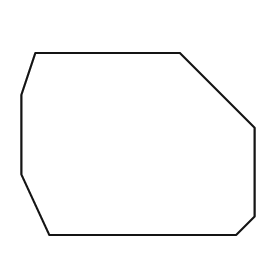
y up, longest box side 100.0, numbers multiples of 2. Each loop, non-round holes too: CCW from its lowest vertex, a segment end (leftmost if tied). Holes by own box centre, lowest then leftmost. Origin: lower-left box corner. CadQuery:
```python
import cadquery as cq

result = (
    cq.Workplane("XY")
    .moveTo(12.0, 0.0)
    .lineTo(92.0, 0.0)
    .lineTo(100.0, 8.0)
    .lineTo(100.0, 46.0)
    .lineTo(68.0, 78.0)
    .lineTo(6.0, 78.0)
    .lineTo(0.0, 60.0)
    .lineTo(0.0, 26.0)
    .close()
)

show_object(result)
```